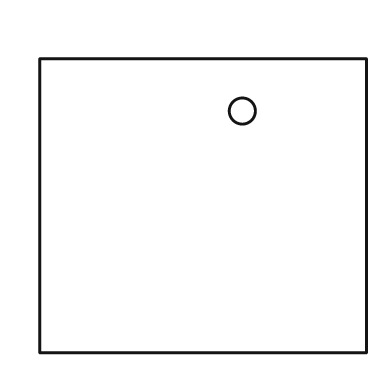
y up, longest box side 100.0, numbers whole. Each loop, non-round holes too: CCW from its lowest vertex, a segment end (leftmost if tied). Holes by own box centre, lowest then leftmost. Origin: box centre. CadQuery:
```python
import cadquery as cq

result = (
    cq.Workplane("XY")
    .moveTo(-50.0, -45.0)
    .lineTo(50.0, -45.0)
    .lineTo(50.0, 45.0)
    .lineTo(-50.0, 45.0)
    .close()
    .moveTo(12.0, 29.0)
    .circle(4.0)
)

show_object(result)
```